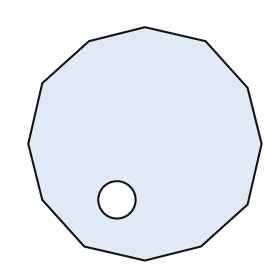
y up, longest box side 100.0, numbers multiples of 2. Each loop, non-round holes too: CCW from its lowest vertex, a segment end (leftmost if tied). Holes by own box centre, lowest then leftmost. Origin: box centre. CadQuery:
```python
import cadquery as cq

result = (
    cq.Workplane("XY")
    .moveTo(0.0, -50.0)
    .lineTo(24.0, -44.0)
    .lineTo(44.0, -26.0)
    .lineTo(50.0, 0.0)
    .lineTo(44.0, 24.0)
    .lineTo(26.0, 44.0)
    .lineTo(0.0, 50.0)
    .lineTo(-24.0, 44.0)
    .lineTo(-44.0, 26.0)
    .lineTo(-50.0, 0.0)
    .lineTo(-44.0, -24.0)
    .lineTo(-26.0, -44.0)
    .close()
    .moveTo(-12.0, -24.0)
    .circle(8.0)
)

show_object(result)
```